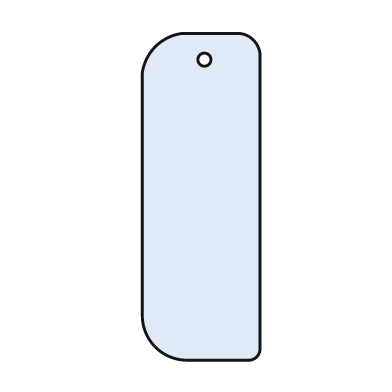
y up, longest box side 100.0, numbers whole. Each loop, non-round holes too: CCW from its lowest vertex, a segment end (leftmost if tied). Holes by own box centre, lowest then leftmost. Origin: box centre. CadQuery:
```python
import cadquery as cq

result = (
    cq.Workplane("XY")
    .moveTo(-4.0, -50.0)
    .lineTo(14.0, -50.0)
    .threePointArc((17.0, -49.0), (18.0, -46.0))
    .lineTo(18.0, 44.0)
    .threePointArc((16.0, 48.0), (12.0, 50.0))
    .lineTo(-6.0, 50.0)
    .threePointArc((-14.0, 46.0), (-18.0, 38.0))
    .lineTo(-18.0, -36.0)
    .threePointArc((-14.0, -46.0), (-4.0, -50.0))
    .close()
    .moveTo(1.0, 42.0)
    .circle(2.0)
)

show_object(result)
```